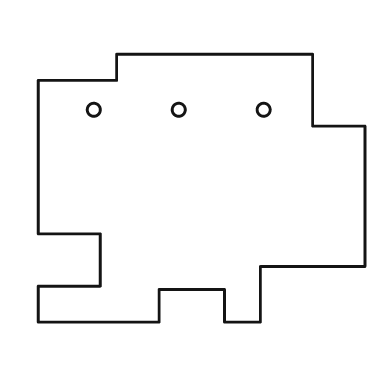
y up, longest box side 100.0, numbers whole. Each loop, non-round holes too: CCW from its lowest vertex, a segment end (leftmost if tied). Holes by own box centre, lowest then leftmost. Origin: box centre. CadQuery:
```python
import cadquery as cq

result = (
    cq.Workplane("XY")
    .moveTo(-50.0, -41.0)
    .lineTo(-13.0, -41.0)
    .lineTo(-13.0, -31.0)
    .lineTo(7.0, -31.0)
    .lineTo(7.0, -41.0)
    .lineTo(18.0, -41.0)
    .lineTo(18.0, -24.0)
    .lineTo(50.0, -24.0)
    .lineTo(50.0, 19.0)
    .lineTo(34.0, 19.0)
    .lineTo(34.0, 41.0)
    .lineTo(-26.0, 41.0)
    .lineTo(-26.0, 33.0)
    .lineTo(-50.0, 33.0)
    .lineTo(-50.0, -14.0)
    .lineTo(-31.0, -14.0)
    .lineTo(-31.0, -30.0)
    .lineTo(-50.0, -30.0)
    .close()
    .moveTo(-33.0, 24.0)
    .circle(2.0)
    .moveTo(-7.0, 24.0)
    .circle(2.0)
    .moveTo(19.0, 24.0)
    .circle(2.0)
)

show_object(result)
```